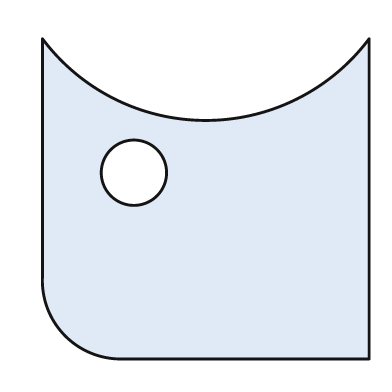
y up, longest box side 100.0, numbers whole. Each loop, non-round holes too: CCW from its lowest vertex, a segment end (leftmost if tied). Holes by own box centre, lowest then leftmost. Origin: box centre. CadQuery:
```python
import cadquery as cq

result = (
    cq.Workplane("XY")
    .moveTo(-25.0, -49.0)
    .lineTo(50.0, -49.0)
    .lineTo(50.0, 49.0)
    .threePointArc((0.0, 24.0), (-50.0, 49.0))
    .lineTo(-50.0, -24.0)
    .threePointArc((-43.0, -42.0), (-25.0, -49.0))
    .close()
    .moveTo(-22.0, 8.0)
    .circle(10.0)
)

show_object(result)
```